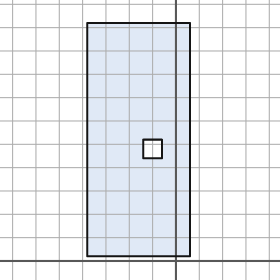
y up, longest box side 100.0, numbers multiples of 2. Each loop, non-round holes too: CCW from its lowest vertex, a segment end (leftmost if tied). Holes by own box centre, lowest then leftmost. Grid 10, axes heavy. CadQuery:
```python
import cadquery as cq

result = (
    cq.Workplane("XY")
    .moveTo(-38.0, 2.0)
    .lineTo(6.0, 2.0)
    .lineTo(6.0, 102.0)
    .lineTo(-38.0, 102.0)
    .close()
    .moveTo(-14.0, 44.0)
    .lineTo(-6.0, 44.0)
    .lineTo(-6.0, 52.0)
    .lineTo(-14.0, 52.0)
    .close()
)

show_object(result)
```